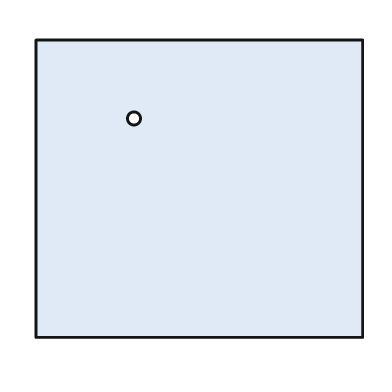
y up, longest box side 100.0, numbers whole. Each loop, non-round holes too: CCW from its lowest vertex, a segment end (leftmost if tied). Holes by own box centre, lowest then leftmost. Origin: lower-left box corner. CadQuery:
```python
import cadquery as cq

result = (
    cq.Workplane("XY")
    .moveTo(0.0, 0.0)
    .lineTo(100.0, 0.0)
    .lineTo(100.0, 91.0)
    .lineTo(0.0, 91.0)
    .close()
    .moveTo(30.0, 67.0)
    .circle(2.0)
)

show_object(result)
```